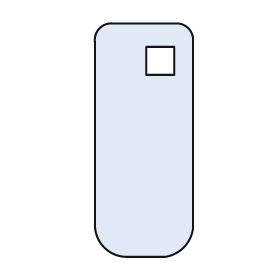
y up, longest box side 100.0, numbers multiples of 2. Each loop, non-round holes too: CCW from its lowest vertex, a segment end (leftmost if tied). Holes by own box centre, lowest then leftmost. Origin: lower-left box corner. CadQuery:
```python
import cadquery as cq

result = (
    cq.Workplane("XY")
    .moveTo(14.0, 0.0)
    .lineTo(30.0, 0.0)
    .threePointArc((38.0, 4.0), (42.0, 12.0))
    .lineTo(42.0, 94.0)
    .threePointArc((40.0, 98.0), (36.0, 100.0))
    .lineTo(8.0, 100.0)
    .threePointArc((2.0, 98.0), (0.0, 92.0))
    .lineTo(0.0, 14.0)
    .threePointArc((4.0, 4.0), (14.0, 0.0))
    .close()
    .moveTo(22.0, 78.0)
    .lineTo(34.0, 78.0)
    .lineTo(34.0, 90.0)
    .lineTo(22.0, 90.0)
    .close()
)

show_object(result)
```